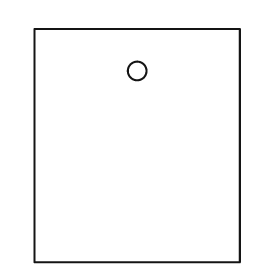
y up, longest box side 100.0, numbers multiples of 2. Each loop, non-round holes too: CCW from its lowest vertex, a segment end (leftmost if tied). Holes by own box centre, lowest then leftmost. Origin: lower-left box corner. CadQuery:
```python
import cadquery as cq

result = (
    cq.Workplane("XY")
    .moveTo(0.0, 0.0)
    .lineTo(88.0, 0.0)
    .lineTo(88.0, 100.0)
    .lineTo(0.0, 100.0)
    .close()
    .moveTo(44.0, 82.0)
    .circle(4.0)
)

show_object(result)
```